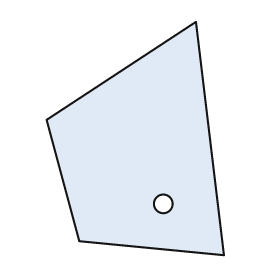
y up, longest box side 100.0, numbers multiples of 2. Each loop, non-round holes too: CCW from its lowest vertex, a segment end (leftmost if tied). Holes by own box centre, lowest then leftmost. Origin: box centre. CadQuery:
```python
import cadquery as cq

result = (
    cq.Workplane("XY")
    .moveTo(38.0, -50.0)
    .lineTo(26.0, 50.0)
    .lineTo(-38.0, 8.0)
    .lineTo(-24.0, -44.0)
    .close()
    .moveTo(12.0, -28.0)
    .circle(4.0)
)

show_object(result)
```